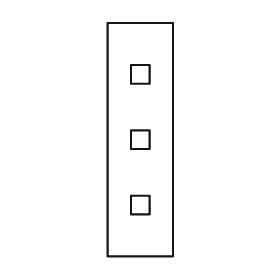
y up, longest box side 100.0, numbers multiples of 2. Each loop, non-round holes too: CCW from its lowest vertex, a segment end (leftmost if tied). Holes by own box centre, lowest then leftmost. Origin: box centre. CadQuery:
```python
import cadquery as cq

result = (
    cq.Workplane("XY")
    .moveTo(-14.0, -50.0)
    .lineTo(14.0, -50.0)
    .lineTo(14.0, 50.0)
    .lineTo(-14.0, 50.0)
    .close()
    .moveTo(-4.0, -32.0)
    .lineTo(4.0, -32.0)
    .lineTo(4.0, -24.0)
    .lineTo(-4.0, -24.0)
    .close()
    .moveTo(-4.0, -4.0)
    .lineTo(4.0, -4.0)
    .lineTo(4.0, 4.0)
    .lineTo(-4.0, 4.0)
    .close()
    .moveTo(-4.0, 24.0)
    .lineTo(4.0, 24.0)
    .lineTo(4.0, 32.0)
    .lineTo(-4.0, 32.0)
    .close()
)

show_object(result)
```